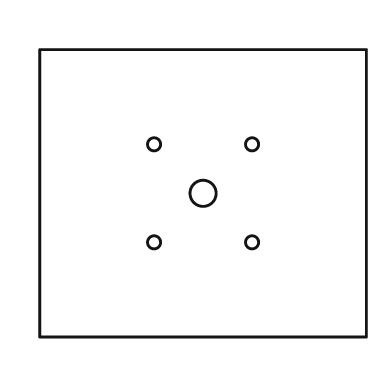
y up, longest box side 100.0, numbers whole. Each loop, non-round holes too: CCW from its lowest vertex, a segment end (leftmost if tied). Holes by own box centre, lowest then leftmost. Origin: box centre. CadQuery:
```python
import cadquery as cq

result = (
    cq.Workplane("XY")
    .moveTo(-50.0, -44.0)
    .lineTo(50.0, -44.0)
    .lineTo(50.0, 44.0)
    .lineTo(-50.0, 44.0)
    .close()
    .moveTo(-15.0, -15.0)
    .circle(2.0)
    .moveTo(15.0, -15.0)
    .circle(2.0)
    .moveTo(0.0, 0.0)
    .circle(4.0)
    .moveTo(-15.0, 15.0)
    .circle(2.0)
    .moveTo(15.0, 15.0)
    .circle(2.0)
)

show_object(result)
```